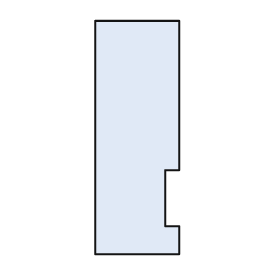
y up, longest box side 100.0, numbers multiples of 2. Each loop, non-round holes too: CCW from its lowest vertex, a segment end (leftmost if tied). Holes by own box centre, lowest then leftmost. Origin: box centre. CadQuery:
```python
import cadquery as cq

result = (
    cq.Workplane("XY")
    .moveTo(-18.0, -50.0)
    .lineTo(18.0, -50.0)
    .lineTo(18.0, -38.0)
    .lineTo(12.0, -38.0)
    .lineTo(12.0, -14.0)
    .lineTo(18.0, -14.0)
    .lineTo(18.0, 50.0)
    .lineTo(-18.0, 50.0)
    .close()
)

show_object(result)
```